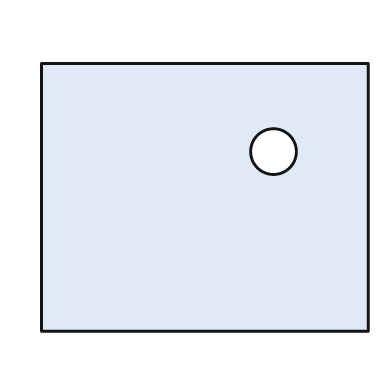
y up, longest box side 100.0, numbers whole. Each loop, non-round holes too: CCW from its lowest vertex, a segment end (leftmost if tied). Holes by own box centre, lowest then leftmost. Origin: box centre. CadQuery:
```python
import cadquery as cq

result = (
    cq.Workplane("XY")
    .moveTo(-50.0, -41.0)
    .lineTo(50.0, -41.0)
    .lineTo(50.0, 41.0)
    .lineTo(-50.0, 41.0)
    .close()
    .moveTo(21.0, 14.0)
    .circle(7.0)
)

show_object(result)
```